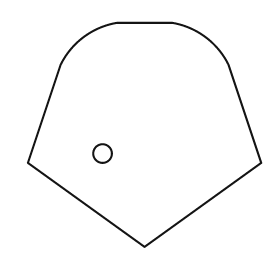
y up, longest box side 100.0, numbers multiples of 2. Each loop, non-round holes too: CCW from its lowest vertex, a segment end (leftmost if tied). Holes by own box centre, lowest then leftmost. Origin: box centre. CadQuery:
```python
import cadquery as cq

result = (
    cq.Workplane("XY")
    .moveTo(0.0, -48.0)
    .lineTo(50.0, -12.0)
    .lineTo(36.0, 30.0)
    .threePointArc((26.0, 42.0), (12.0, 48.0))
    .lineTo(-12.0, 48.0)
    .threePointArc((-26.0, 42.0), (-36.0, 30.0))
    .lineTo(-50.0, -12.0)
    .close()
    .moveTo(-18.0, -8.0)
    .circle(4.0)
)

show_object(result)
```